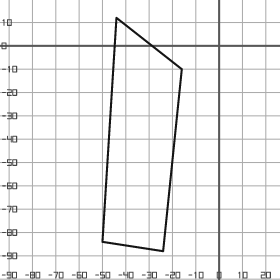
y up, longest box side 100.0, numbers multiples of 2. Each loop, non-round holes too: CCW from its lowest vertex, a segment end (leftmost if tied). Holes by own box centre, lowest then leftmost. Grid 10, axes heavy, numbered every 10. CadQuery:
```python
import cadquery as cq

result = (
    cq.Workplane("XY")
    .moveTo(-24.0, -88.0)
    .lineTo(-16.0, -10.0)
    .lineTo(-44.0, 12.0)
    .lineTo(-50.0, -84.0)
    .close()
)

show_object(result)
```